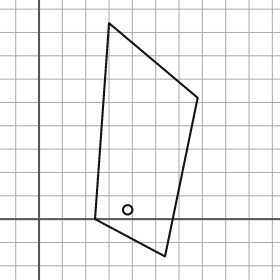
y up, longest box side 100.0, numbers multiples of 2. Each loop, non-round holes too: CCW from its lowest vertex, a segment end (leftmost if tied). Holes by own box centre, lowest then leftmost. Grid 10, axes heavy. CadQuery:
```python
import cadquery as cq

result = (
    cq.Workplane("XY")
    .moveTo(54.0, -16.0)
    .lineTo(68.0, 52.0)
    .lineTo(30.0, 84.0)
    .lineTo(24.0, 0.0)
    .close()
    .moveTo(38.0, 4.0)
    .circle(2.0)
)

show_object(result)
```